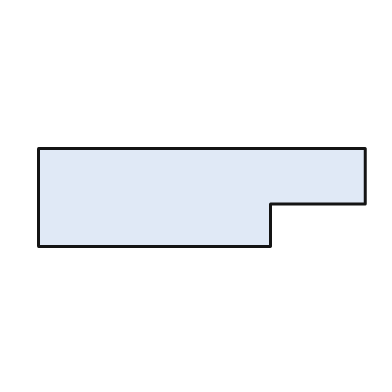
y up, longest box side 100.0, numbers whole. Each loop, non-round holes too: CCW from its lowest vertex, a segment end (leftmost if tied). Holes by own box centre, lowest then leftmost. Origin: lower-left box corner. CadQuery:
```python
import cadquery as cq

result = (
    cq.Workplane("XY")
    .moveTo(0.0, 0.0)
    .lineTo(71.0, 0.0)
    .lineTo(71.0, 13.0)
    .lineTo(100.0, 13.0)
    .lineTo(100.0, 30.0)
    .lineTo(0.0, 30.0)
    .close()
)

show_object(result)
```